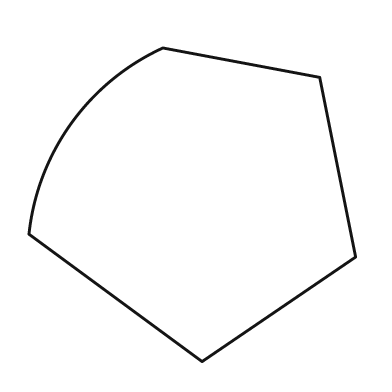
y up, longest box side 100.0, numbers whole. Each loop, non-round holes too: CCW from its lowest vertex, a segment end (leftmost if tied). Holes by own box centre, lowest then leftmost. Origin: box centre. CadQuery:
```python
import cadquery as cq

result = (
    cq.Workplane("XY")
    .moveTo(3.0, -48.0)
    .lineTo(50.0, -16.0)
    .lineTo(39.0, 39.0)
    .lineTo(-9.0, 48.0)
    .threePointArc((-37.0, 25.0), (-50.0, -9.0))
    .close()
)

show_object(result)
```